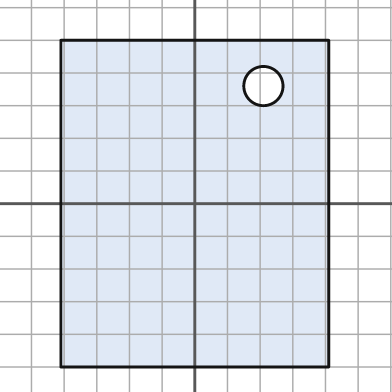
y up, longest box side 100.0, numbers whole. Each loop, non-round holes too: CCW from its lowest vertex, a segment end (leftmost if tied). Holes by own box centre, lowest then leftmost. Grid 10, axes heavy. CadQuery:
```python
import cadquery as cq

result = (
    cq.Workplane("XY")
    .moveTo(-41.0, -50.0)
    .lineTo(41.0, -50.0)
    .lineTo(41.0, 50.0)
    .lineTo(-41.0, 50.0)
    .close()
    .moveTo(21.0, 36.0)
    .circle(6.0)
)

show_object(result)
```